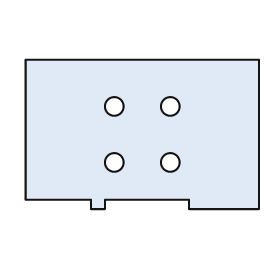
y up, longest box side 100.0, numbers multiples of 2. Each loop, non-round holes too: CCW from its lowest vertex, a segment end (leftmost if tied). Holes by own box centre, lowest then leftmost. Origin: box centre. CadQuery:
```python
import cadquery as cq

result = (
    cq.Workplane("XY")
    .moveTo(-22.0, -32.0)
    .lineTo(-16.0, -32.0)
    .lineTo(-16.0, -28.0)
    .lineTo(20.0, -28.0)
    .lineTo(20.0, -32.0)
    .lineTo(50.0, -32.0)
    .lineTo(50.0, 32.0)
    .lineTo(-50.0, 32.0)
    .lineTo(-50.0, -28.0)
    .lineTo(-22.0, -28.0)
    .close()
    .moveTo(-12.0, -12.0)
    .circle(4.0)
    .moveTo(12.0, -12.0)
    .circle(4.0)
    .moveTo(-12.0, 12.0)
    .circle(4.0)
    .moveTo(12.0, 12.0)
    .circle(4.0)
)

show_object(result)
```